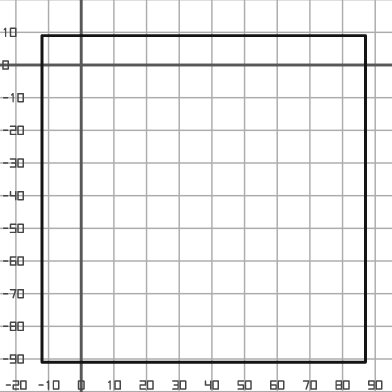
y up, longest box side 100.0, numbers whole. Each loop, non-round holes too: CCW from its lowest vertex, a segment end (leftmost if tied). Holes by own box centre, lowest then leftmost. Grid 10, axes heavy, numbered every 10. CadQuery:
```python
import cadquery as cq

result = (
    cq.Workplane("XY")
    .moveTo(-12.0, -91.0)
    .lineTo(87.0, -91.0)
    .lineTo(87.0, 9.0)
    .lineTo(-12.0, 9.0)
    .close()
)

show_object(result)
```